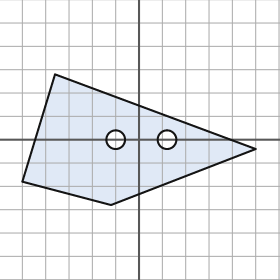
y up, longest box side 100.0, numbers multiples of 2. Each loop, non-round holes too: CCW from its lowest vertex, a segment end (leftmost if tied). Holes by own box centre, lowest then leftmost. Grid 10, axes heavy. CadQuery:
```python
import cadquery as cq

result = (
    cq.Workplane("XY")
    .moveTo(-12.0, -28.0)
    .lineTo(50.0, -4.0)
    .lineTo(-36.0, 28.0)
    .lineTo(-50.0, -18.0)
    .close()
    .moveTo(-10.0, 0.0)
    .circle(4.0)
    .moveTo(12.0, 0.0)
    .circle(4.0)
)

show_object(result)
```